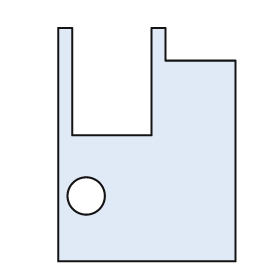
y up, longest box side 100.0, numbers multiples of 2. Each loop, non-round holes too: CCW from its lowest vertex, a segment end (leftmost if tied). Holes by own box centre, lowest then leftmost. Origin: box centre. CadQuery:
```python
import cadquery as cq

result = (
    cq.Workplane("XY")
    .moveTo(-38.0, -50.0)
    .lineTo(38.0, -50.0)
    .lineTo(38.0, 36.0)
    .lineTo(8.0, 36.0)
    .lineTo(8.0, 50.0)
    .lineTo(2.0, 50.0)
    .lineTo(2.0, 4.0)
    .lineTo(-32.0, 4.0)
    .lineTo(-32.0, 50.0)
    .lineTo(-38.0, 50.0)
    .close()
    .moveTo(-26.0, -22.0)
    .circle(8.0)
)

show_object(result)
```